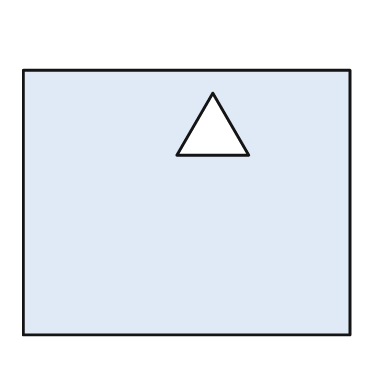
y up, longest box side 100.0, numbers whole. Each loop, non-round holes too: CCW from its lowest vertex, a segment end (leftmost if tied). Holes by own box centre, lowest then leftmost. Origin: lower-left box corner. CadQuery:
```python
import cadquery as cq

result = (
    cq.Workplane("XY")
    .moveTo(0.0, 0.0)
    .lineTo(100.0, 0.0)
    .lineTo(100.0, 81.0)
    .lineTo(0.0, 81.0)
    .close()
    .moveTo(47.0, 55.0)
    .lineTo(69.0, 55.0)
    .lineTo(58.0, 74.0)
    .close()
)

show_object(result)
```